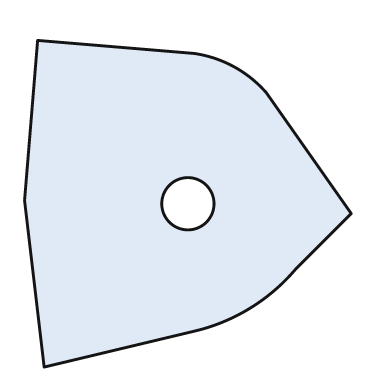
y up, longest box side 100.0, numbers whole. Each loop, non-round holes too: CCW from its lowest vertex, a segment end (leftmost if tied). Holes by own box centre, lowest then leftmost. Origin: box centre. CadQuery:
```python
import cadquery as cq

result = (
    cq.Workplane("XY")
    .moveTo(-44.0, -50.0)
    .lineTo(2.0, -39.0)
    .threePointArc((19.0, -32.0), (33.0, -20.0))
    .lineTo(50.0, -3.0)
    .lineTo(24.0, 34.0)
    .threePointArc((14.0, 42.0), (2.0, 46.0))
    .lineTo(-46.0, 50.0)
    .lineTo(-50.0, 1.0)
    .close()
    .moveTo(0.0, 0.0)
    .circle(8.0)
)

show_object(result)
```